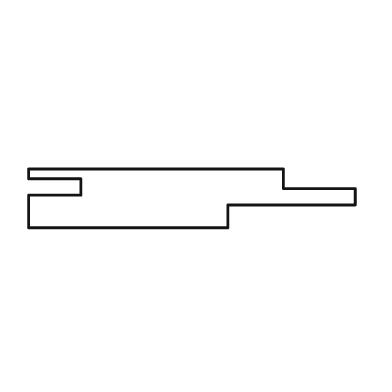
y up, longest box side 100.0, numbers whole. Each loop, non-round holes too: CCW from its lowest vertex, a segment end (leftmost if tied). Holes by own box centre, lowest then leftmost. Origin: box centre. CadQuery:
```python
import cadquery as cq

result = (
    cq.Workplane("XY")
    .moveTo(-50.0, -9.0)
    .lineTo(11.0, -9.0)
    .lineTo(11.0, -2.0)
    .lineTo(50.0, -2.0)
    .lineTo(50.0, 3.0)
    .lineTo(28.0, 3.0)
    .lineTo(28.0, 9.0)
    .lineTo(-50.0, 9.0)
    .lineTo(-50.0, 6.0)
    .lineTo(-34.0, 6.0)
    .lineTo(-34.0, 1.0)
    .lineTo(-50.0, 1.0)
    .close()
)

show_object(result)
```